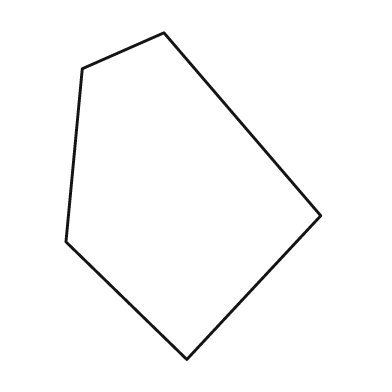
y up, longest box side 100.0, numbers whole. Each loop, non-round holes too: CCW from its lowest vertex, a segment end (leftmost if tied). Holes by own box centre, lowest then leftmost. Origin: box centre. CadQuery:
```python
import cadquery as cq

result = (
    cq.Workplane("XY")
    .moveTo(-2.0, -50.0)
    .lineTo(39.0, -6.0)
    .lineTo(-9.0, 50.0)
    .lineTo(-34.0, 39.0)
    .lineTo(-39.0, -14.0)
    .close()
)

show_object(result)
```